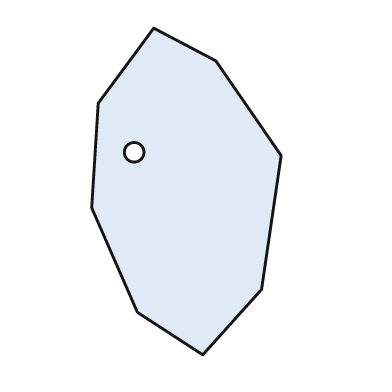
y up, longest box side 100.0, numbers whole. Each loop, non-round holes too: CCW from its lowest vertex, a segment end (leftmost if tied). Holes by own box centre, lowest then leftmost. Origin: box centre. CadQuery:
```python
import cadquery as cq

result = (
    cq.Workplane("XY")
    .moveTo(5.0, -50.0)
    .lineTo(23.0, -30.0)
    .lineTo(29.0, 11.0)
    .lineTo(9.0, 40.0)
    .lineTo(-10.0, 50.0)
    .lineTo(-27.0, 27.0)
    .lineTo(-29.0, -5.0)
    .lineTo(-15.0, -37.0)
    .close()
    .moveTo(-16.0, 12.0)
    .circle(3.0)
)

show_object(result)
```